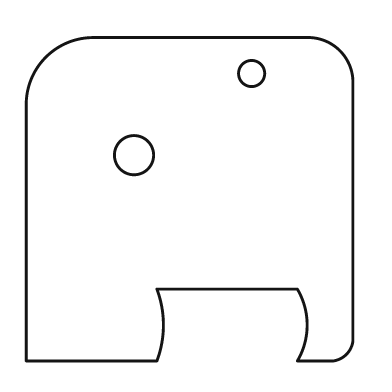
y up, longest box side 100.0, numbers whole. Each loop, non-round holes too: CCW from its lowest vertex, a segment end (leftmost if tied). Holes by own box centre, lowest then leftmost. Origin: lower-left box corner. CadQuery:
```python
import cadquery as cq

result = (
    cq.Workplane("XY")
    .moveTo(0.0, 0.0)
    .lineTo(40.0, 0.0)
    .threePointArc((42.0, 11.0), (40.0, 22.0))
    .lineTo(83.0, 22.0)
    .threePointArc((86.0, 11.0), (83.0, 0.0))
    .lineTo(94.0, 0.0)
    .threePointArc((98.0, 2.0), (100.0, 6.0))
    .lineTo(100.0, 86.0)
    .threePointArc((96.0, 95.0), (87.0, 99.0))
    .lineTo(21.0, 99.0)
    .threePointArc((6.0, 93.0), (0.0, 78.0))
    .close()
    .moveTo(33.0, 63.0)
    .circle(6.0)
    .moveTo(69.0, 88.0)
    .circle(4.0)
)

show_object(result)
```